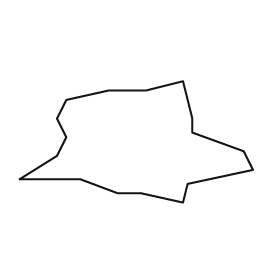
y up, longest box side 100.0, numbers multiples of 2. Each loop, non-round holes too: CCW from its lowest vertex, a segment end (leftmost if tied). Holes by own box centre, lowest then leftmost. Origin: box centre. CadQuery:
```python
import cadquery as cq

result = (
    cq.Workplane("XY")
    .moveTo(20.0, -26.0)
    .lineTo(22.0, -18.0)
    .lineTo(50.0, -12.0)
    .lineTo(46.0, -4.0)
    .lineTo(24.0, 4.0)
    .lineTo(24.0, 10.0)
    .lineTo(20.0, 26.0)
    .lineTo(4.0, 22.0)
    .lineTo(-12.0, 22.0)
    .lineTo(-30.0, 18.0)
    .lineTo(-34.0, 10.0)
    .lineTo(-30.0, 2.0)
    .lineTo(-34.0, -6.0)
    .lineTo(-50.0, -16.0)
    .lineTo(-24.0, -16.0)
    .lineTo(-8.0, -22.0)
    .lineTo(2.0, -22.0)
    .close()
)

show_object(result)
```